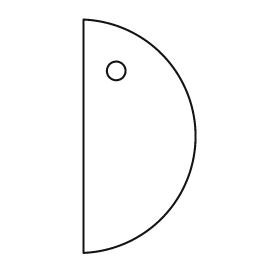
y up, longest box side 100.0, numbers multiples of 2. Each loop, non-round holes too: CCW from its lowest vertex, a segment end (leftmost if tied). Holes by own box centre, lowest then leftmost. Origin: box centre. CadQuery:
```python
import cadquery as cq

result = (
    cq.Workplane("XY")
    .moveTo(-24.0, -50.0)
    .threePointArc((24.0, 0.0), (-24.0, 50.0))
    .close()
    .moveTo(-10.0, 28.0)
    .circle(4.0)
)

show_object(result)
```